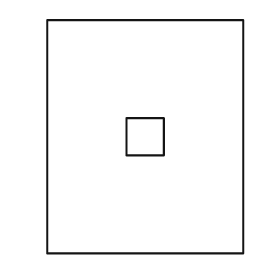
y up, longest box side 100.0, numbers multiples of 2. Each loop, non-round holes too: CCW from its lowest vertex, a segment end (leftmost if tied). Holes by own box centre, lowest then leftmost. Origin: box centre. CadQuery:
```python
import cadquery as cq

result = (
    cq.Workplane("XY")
    .moveTo(-42.0, -50.0)
    .lineTo(42.0, -50.0)
    .lineTo(42.0, 50.0)
    .lineTo(-42.0, 50.0)
    .close()
    .moveTo(-8.0, -8.0)
    .lineTo(8.0, -8.0)
    .lineTo(8.0, 8.0)
    .lineTo(-8.0, 8.0)
    .close()
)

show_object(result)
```